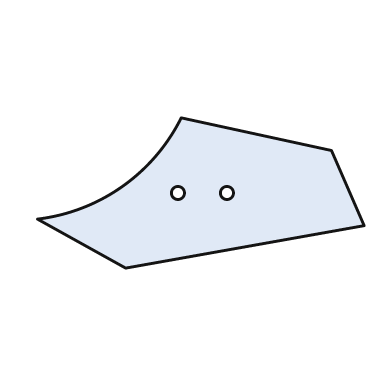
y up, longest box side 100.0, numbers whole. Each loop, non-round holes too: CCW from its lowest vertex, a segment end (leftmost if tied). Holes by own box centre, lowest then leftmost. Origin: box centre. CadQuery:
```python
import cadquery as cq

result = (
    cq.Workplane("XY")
    .moveTo(-23.0, -23.0)
    .lineTo(50.0, -10.0)
    .lineTo(40.0, 13.0)
    .lineTo(-6.0, 23.0)
    .threePointArc((-24.0, 2.0), (-50.0, -8.0))
    .close()
    .moveTo(-7.0, 0.0)
    .circle(2.0)
    .moveTo(8.0, 0.0)
    .circle(2.0)
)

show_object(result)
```